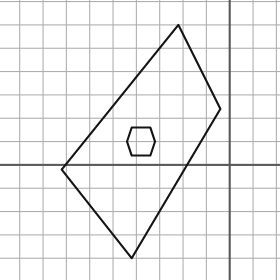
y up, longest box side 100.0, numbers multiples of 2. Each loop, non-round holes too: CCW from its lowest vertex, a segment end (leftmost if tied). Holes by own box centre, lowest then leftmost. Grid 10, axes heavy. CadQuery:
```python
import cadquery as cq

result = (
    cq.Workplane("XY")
    .moveTo(-42.0, -40.0)
    .lineTo(-4.0, 24.0)
    .lineTo(-22.0, 60.0)
    .lineTo(-72.0, -2.0)
    .close()
    .moveTo(-42.0, 4.0)
    .lineTo(-34.0, 4.0)
    .lineTo(-32.0, 10.0)
    .lineTo(-34.0, 16.0)
    .lineTo(-42.0, 16.0)
    .lineTo(-44.0, 10.0)
    .close()
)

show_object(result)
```